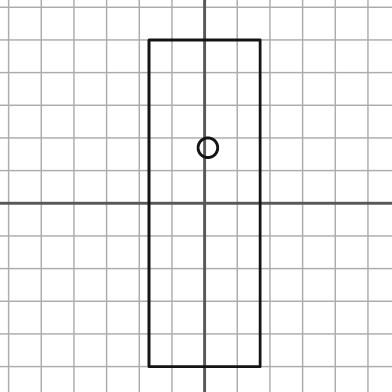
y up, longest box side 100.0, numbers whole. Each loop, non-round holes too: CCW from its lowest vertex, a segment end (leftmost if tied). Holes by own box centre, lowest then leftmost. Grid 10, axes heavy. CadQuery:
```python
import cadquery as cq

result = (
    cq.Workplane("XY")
    .moveTo(-17.0, -50.0)
    .lineTo(17.0, -50.0)
    .lineTo(17.0, 50.0)
    .lineTo(-17.0, 50.0)
    .close()
    .moveTo(1.0, 17.0)
    .circle(3.0)
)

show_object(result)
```